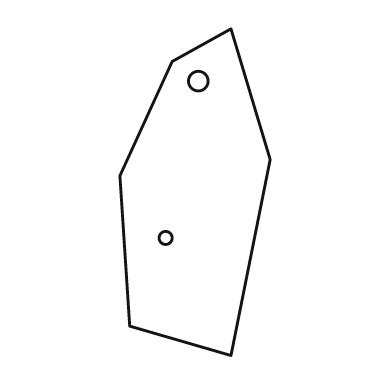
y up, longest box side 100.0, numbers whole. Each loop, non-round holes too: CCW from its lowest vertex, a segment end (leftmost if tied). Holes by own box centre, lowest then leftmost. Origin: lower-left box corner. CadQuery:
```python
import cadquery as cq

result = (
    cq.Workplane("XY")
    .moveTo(34.0, 0.0)
    .lineTo(46.0, 60.0)
    .lineTo(34.0, 100.0)
    .lineTo(16.0, 90.0)
    .lineTo(0.0, 55.0)
    .lineTo(3.0, 9.0)
    .close()
    .moveTo(14.0, 36.0)
    .circle(2.0)
    .moveTo(24.0, 84.0)
    .circle(3.0)
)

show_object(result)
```